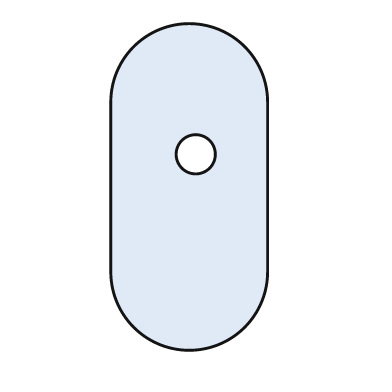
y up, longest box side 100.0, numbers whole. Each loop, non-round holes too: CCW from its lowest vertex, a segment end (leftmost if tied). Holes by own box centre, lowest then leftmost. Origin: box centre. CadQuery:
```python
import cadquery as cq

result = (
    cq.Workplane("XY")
    .moveTo(-24.0, -26.0)
    .threePointArc((0.0, -50.0), (24.0, -26.0))
    .lineTo(24.0, 26.0)
    .threePointArc((0.0, 50.0), (-24.0, 26.0))
    .close()
    .moveTo(2.0, 10.0)
    .circle(6.0)
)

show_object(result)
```